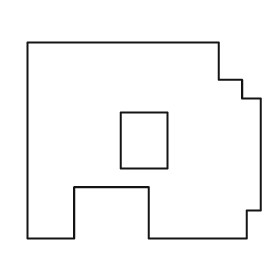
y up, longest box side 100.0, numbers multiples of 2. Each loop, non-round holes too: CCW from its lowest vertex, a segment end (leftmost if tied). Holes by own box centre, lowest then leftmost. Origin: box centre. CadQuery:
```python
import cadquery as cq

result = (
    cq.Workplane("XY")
    .moveTo(-50.0, -42.0)
    .lineTo(-30.0, -42.0)
    .lineTo(-30.0, -20.0)
    .lineTo(2.0, -20.0)
    .lineTo(2.0, -42.0)
    .lineTo(44.0, -42.0)
    .lineTo(44.0, -30.0)
    .lineTo(50.0, -30.0)
    .lineTo(50.0, 18.0)
    .lineTo(42.0, 18.0)
    .lineTo(42.0, 26.0)
    .lineTo(32.0, 26.0)
    .lineTo(32.0, 42.0)
    .lineTo(-50.0, 42.0)
    .close()
    .moveTo(-10.0, -12.0)
    .lineTo(10.0, -12.0)
    .lineTo(10.0, 12.0)
    .lineTo(-10.0, 12.0)
    .close()
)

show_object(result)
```